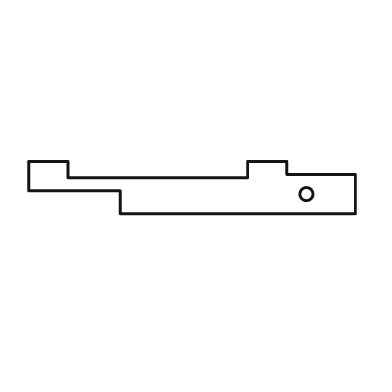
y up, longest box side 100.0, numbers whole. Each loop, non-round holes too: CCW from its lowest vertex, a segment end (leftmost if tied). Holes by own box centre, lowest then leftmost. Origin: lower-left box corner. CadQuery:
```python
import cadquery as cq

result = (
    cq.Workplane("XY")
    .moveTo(28.0, 0.0)
    .lineTo(100.0, 0.0)
    .lineTo(100.0, 12.0)
    .lineTo(79.0, 12.0)
    .lineTo(79.0, 16.0)
    .lineTo(67.0, 16.0)
    .lineTo(67.0, 11.0)
    .lineTo(12.0, 11.0)
    .lineTo(12.0, 16.0)
    .lineTo(0.0, 16.0)
    .lineTo(0.0, 7.0)
    .lineTo(28.0, 7.0)
    .close()
    .moveTo(85.0, 6.0)
    .circle(2.0)
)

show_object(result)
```